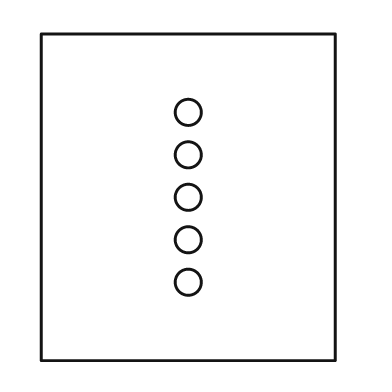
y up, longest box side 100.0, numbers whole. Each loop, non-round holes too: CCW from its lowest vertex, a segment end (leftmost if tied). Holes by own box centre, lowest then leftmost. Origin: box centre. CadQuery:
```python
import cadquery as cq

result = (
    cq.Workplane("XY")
    .moveTo(-45.0, -50.0)
    .lineTo(45.0, -50.0)
    .lineTo(45.0, 50.0)
    .lineTo(-45.0, 50.0)
    .close()
    .moveTo(0.0, -26.0)
    .circle(4.0)
    .moveTo(0.0, -13.0)
    .circle(4.0)
    .moveTo(0.0, 0.0)
    .circle(4.0)
    .moveTo(0.0, 13.0)
    .circle(4.0)
    .moveTo(0.0, 26.0)
    .circle(4.0)
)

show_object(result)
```